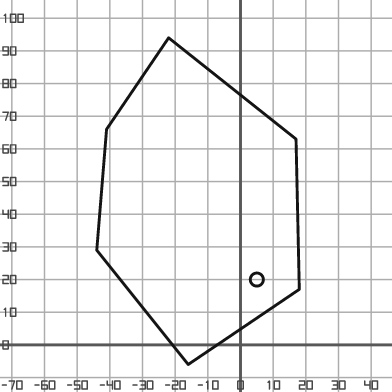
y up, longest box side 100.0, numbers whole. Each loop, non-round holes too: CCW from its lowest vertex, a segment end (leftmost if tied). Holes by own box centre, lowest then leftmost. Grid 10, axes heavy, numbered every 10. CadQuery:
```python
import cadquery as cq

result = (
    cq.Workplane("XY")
    .moveTo(-16.0, -6.0)
    .lineTo(18.0, 17.0)
    .lineTo(17.0, 63.0)
    .lineTo(-22.0, 94.0)
    .lineTo(-41.0, 66.0)
    .lineTo(-44.0, 29.0)
    .close()
    .moveTo(5.0, 20.0)
    .circle(2.0)
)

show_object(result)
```